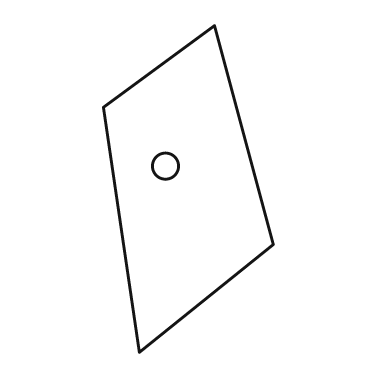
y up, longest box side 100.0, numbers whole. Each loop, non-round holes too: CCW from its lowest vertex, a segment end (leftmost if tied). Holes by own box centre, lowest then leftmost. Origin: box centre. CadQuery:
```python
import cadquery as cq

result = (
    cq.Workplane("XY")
    .moveTo(-15.0, -50.0)
    .lineTo(26.0, -17.0)
    .lineTo(8.0, 50.0)
    .lineTo(-26.0, 25.0)
    .close()
    .moveTo(-7.0, 7.0)
    .circle(4.0)
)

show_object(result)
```